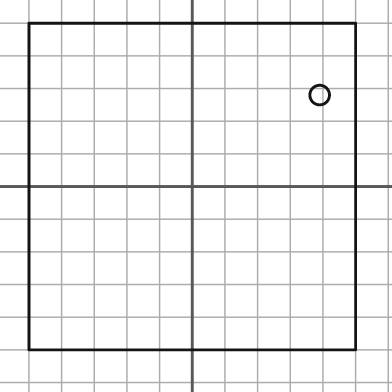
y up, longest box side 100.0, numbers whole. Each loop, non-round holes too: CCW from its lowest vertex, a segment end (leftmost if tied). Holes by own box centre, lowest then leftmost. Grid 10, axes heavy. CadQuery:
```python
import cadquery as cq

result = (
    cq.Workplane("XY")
    .moveTo(-50.0, -50.0)
    .lineTo(50.0, -50.0)
    .lineTo(50.0, 50.0)
    .lineTo(-50.0, 50.0)
    .close()
    .moveTo(39.0, 28.0)
    .circle(3.0)
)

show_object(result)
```